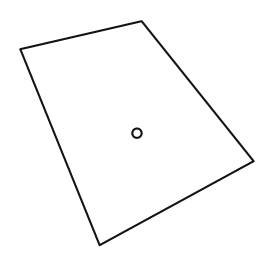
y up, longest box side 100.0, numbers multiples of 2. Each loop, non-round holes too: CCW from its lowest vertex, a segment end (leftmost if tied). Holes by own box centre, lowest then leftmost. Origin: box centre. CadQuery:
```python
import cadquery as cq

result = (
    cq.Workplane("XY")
    .moveTo(-16.0, -48.0)
    .lineTo(50.0, -12.0)
    .lineTo(2.0, 48.0)
    .lineTo(-50.0, 36.0)
    .close()
    .moveTo(0.0, 0.0)
    .circle(2.0)
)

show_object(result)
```